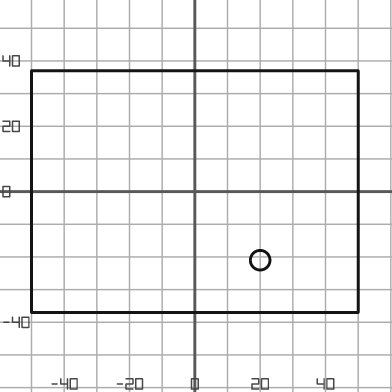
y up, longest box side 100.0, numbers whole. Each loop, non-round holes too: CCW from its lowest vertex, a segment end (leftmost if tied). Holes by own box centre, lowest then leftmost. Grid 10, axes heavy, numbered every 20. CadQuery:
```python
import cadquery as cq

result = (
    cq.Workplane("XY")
    .moveTo(-50.0, -37.0)
    .lineTo(50.0, -37.0)
    .lineTo(50.0, 37.0)
    .lineTo(-50.0, 37.0)
    .close()
    .moveTo(20.0, -21.0)
    .circle(3.0)
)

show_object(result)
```